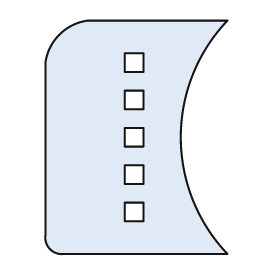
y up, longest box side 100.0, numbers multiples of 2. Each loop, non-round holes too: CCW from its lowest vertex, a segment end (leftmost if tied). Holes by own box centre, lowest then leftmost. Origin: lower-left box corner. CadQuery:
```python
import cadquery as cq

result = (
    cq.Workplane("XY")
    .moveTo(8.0, 0.0)
    .lineTo(78.0, 0.0)
    .threePointArc((58.0, 50.0), (78.0, 100.0))
    .lineTo(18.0, 100.0)
    .threePointArc((6.0, 94.0), (0.0, 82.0))
    .lineTo(0.0, 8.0)
    .threePointArc((2.0, 2.0), (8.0, 0.0))
    .close()
    .moveTo(34.0, 14.0)
    .lineTo(42.0, 14.0)
    .lineTo(42.0, 22.0)
    .lineTo(34.0, 22.0)
    .close()
    .moveTo(34.0, 30.0)
    .lineTo(42.0, 30.0)
    .lineTo(42.0, 38.0)
    .lineTo(34.0, 38.0)
    .close()
    .moveTo(34.0, 46.0)
    .lineTo(42.0, 46.0)
    .lineTo(42.0, 54.0)
    .lineTo(34.0, 54.0)
    .close()
    .moveTo(34.0, 62.0)
    .lineTo(42.0, 62.0)
    .lineTo(42.0, 70.0)
    .lineTo(34.0, 70.0)
    .close()
    .moveTo(34.0, 78.0)
    .lineTo(42.0, 78.0)
    .lineTo(42.0, 86.0)
    .lineTo(34.0, 86.0)
    .close()
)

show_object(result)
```